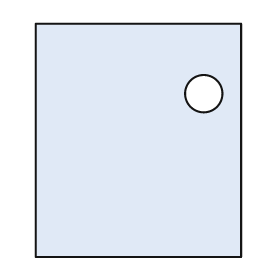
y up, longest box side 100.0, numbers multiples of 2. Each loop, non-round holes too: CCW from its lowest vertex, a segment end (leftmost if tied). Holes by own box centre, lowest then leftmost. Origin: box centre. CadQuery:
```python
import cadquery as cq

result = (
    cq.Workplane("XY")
    .moveTo(-44.0, -50.0)
    .lineTo(44.0, -50.0)
    .lineTo(44.0, 50.0)
    .lineTo(-44.0, 50.0)
    .close()
    .moveTo(28.0, 20.0)
    .circle(8.0)
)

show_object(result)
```